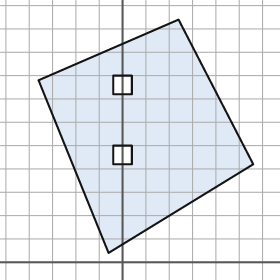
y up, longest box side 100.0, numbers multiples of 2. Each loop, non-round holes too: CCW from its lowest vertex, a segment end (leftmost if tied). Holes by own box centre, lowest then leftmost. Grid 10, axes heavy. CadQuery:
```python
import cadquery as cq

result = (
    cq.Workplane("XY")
    .moveTo(-6.0, 4.0)
    .lineTo(56.0, 42.0)
    .lineTo(24.0, 104.0)
    .lineTo(-36.0, 78.0)
    .close()
    .moveTo(-4.0, 42.0)
    .lineTo(4.0, 42.0)
    .lineTo(4.0, 50.0)
    .lineTo(-4.0, 50.0)
    .close()
    .moveTo(-4.0, 72.0)
    .lineTo(4.0, 72.0)
    .lineTo(4.0, 80.0)
    .lineTo(-4.0, 80.0)
    .close()
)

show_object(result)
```